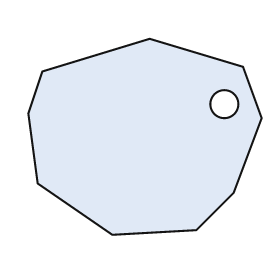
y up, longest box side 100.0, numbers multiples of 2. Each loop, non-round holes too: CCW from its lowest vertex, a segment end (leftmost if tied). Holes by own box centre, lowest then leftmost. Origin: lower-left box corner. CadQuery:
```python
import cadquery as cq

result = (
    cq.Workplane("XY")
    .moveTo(36.0, 0.0)
    .lineTo(72.0, 2.0)
    .lineTo(88.0, 18.0)
    .lineTo(100.0, 50.0)
    .lineTo(92.0, 72.0)
    .lineTo(52.0, 84.0)
    .lineTo(6.0, 70.0)
    .lineTo(0.0, 52.0)
    .lineTo(4.0, 22.0)
    .close()
    .moveTo(84.0, 56.0)
    .circle(6.0)
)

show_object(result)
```